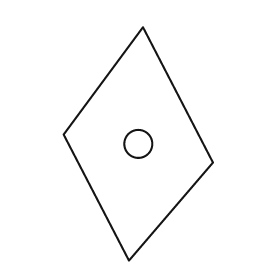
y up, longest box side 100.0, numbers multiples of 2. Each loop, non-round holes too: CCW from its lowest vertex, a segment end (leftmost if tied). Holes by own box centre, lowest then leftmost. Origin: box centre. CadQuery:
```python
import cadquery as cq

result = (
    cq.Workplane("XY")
    .moveTo(-4.0, -50.0)
    .lineTo(32.0, -8.0)
    .lineTo(2.0, 50.0)
    .lineTo(-32.0, 4.0)
    .close()
    .moveTo(0.0, 0.0)
    .circle(6.0)
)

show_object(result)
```